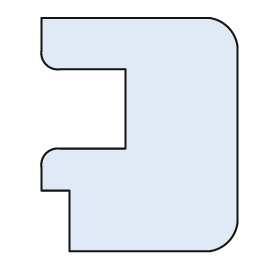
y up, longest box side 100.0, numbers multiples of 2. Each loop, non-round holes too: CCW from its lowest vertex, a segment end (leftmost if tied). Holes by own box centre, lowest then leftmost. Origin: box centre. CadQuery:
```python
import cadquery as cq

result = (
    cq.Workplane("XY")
    .moveTo(-30.0, -50.0)
    .lineTo(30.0, -50.0)
    .threePointArc((38.0, -46.0), (42.0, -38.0))
    .lineTo(42.0, 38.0)
    .threePointArc((38.0, 46.0), (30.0, 50.0))
    .lineTo(-42.0, 50.0)
    .lineTo(-42.0, 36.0)
    .threePointArc((-40.0, 30.0), (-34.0, 28.0))
    .lineTo(-6.0, 28.0)
    .lineTo(-6.0, -6.0)
    .lineTo(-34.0, -6.0)
    .threePointArc((-40.0, -8.0), (-42.0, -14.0))
    .lineTo(-42.0, -24.0)
    .lineTo(-30.0, -24.0)
    .close()
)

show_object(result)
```